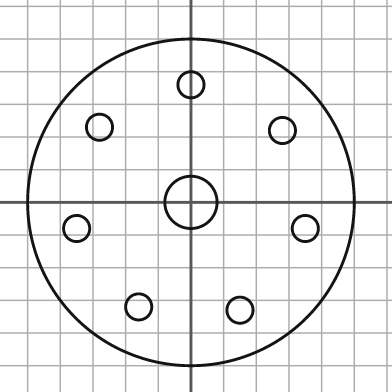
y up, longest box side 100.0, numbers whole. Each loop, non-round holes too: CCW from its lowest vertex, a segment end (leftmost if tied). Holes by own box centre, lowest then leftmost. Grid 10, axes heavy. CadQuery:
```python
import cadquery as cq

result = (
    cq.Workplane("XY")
    .moveTo(0.0, 0.0)
    .circle(50.0)
    .moveTo(15.0, -33.0)
    .circle(4.0)
    .moveTo(-16.0, -32.0)
    .circle(4.0)
    .moveTo(-35.0, -8.0)
    .circle(4.0)
    .moveTo(35.0, -8.0)
    .circle(4.0)
    .moveTo(0.0, 0.0)
    .circle(8.0)
    .moveTo(28.0, 22.0)
    .circle(4.0)
    .moveTo(-28.0, 23.0)
    .circle(4.0)
    .moveTo(0.0, 36.0)
    .circle(4.0)
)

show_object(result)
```